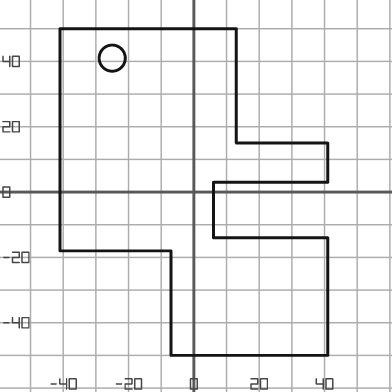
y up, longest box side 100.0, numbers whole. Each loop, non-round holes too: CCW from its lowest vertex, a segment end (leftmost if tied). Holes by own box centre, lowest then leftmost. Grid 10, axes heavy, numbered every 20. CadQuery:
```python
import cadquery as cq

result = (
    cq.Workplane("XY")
    .moveTo(-7.0, -50.0)
    .lineTo(41.0, -50.0)
    .lineTo(41.0, -14.0)
    .lineTo(6.0, -14.0)
    .lineTo(6.0, 3.0)
    .lineTo(41.0, 3.0)
    .lineTo(41.0, 15.0)
    .lineTo(13.0, 15.0)
    .lineTo(13.0, 50.0)
    .lineTo(-41.0, 50.0)
    .lineTo(-41.0, -18.0)
    .lineTo(-7.0, -18.0)
    .close()
    .moveTo(-25.0, 41.0)
    .circle(4.0)
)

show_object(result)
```